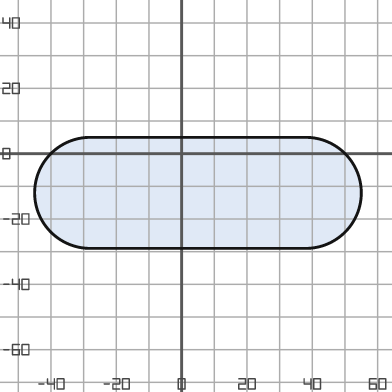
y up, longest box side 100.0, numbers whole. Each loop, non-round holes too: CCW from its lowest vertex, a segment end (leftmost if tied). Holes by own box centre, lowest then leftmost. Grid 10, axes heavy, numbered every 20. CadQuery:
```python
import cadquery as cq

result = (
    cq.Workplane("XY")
    .moveTo(-28.0, -29.0)
    .lineTo(38.0, -29.0)
    .threePointArc((55.0, -12.0), (38.0, 5.0))
    .lineTo(-28.0, 5.0)
    .threePointArc((-45.0, -12.0), (-28.0, -29.0))
    .close()
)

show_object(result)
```